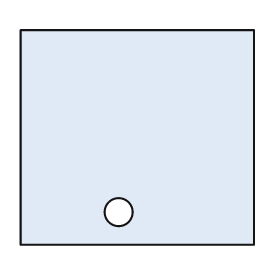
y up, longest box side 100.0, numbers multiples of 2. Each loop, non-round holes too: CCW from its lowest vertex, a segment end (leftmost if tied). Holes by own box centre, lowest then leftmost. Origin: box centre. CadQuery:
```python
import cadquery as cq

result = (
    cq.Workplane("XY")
    .moveTo(-50.0, -46.0)
    .lineTo(50.0, -46.0)
    .lineTo(50.0, 46.0)
    .lineTo(-50.0, 46.0)
    .close()
    .moveTo(-8.0, -32.0)
    .circle(6.0)
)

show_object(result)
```